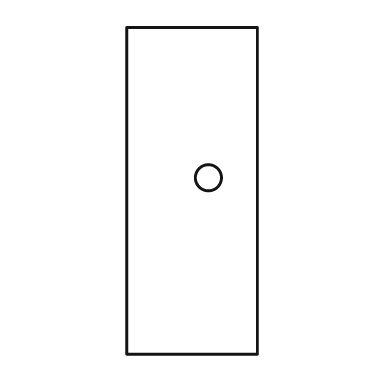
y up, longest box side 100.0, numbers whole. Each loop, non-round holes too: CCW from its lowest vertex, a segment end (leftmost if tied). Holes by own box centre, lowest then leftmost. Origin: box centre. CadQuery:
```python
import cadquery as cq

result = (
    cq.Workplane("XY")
    .moveTo(-20.0, -50.0)
    .lineTo(20.0, -50.0)
    .lineTo(20.0, 50.0)
    .lineTo(-20.0, 50.0)
    .close()
    .moveTo(5.0, 4.0)
    .circle(4.0)
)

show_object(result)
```